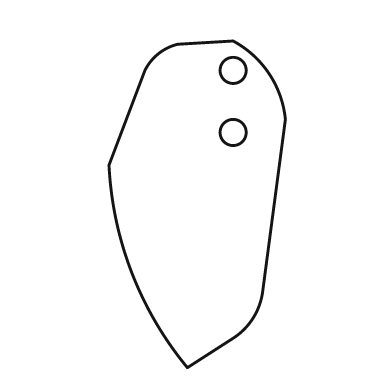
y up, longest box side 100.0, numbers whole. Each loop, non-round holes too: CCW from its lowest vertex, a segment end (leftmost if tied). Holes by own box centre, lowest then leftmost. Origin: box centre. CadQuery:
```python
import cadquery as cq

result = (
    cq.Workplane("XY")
    .moveTo(-3.0, -50.0)
    .lineTo(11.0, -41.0)
    .threePointArc((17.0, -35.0), (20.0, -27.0))
    .lineTo(27.0, 26.0)
    .threePointArc((22.0, 40.0), (11.0, 50.0))
    .lineTo(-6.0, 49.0)
    .threePointArc((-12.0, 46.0), (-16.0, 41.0))
    .lineTo(-27.0, 12.0)
    .threePointArc((-20.0, -21.0), (-3.0, -50.0))
    .close()
    .moveTo(11.0, 22.0)
    .circle(4.0)
    .moveTo(11.0, 41.0)
    .circle(4.0)
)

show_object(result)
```